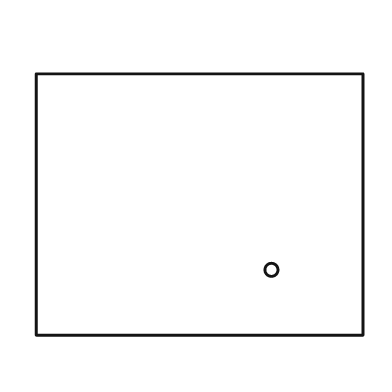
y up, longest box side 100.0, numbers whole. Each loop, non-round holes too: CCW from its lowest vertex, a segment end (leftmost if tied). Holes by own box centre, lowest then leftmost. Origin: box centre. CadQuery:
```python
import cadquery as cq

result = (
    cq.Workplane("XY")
    .moveTo(-50.0, -40.0)
    .lineTo(50.0, -40.0)
    .lineTo(50.0, 40.0)
    .lineTo(-50.0, 40.0)
    .close()
    .moveTo(22.0, -20.0)
    .circle(2.0)
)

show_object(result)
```